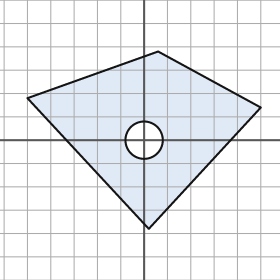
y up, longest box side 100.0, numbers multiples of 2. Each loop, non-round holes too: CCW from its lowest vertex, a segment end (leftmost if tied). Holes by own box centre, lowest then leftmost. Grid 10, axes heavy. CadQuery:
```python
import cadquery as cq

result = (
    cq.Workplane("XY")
    .moveTo(2.0, -38.0)
    .lineTo(50.0, 14.0)
    .lineTo(6.0, 38.0)
    .lineTo(-50.0, 18.0)
    .close()
    .moveTo(0.0, 0.0)
    .circle(8.0)
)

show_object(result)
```